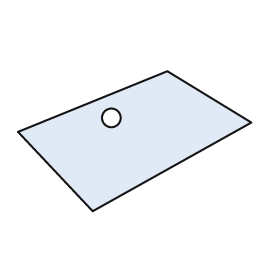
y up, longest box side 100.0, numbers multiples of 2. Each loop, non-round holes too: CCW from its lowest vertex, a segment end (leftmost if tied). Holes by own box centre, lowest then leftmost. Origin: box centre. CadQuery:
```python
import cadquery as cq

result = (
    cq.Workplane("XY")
    .moveTo(-18.0, -30.0)
    .lineTo(50.0, 8.0)
    .lineTo(14.0, 30.0)
    .lineTo(-50.0, 4.0)
    .close()
    .moveTo(-10.0, 10.0)
    .circle(4.0)
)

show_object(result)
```